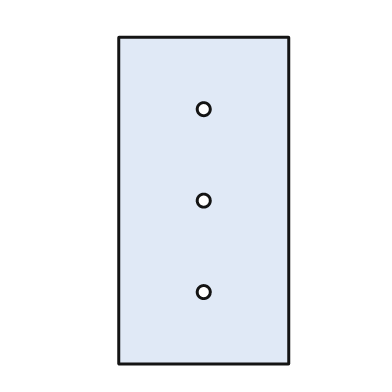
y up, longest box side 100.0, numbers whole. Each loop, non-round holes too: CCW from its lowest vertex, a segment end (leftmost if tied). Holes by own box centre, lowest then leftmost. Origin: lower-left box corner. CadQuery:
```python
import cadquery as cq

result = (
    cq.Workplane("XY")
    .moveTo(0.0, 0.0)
    .lineTo(52.0, 0.0)
    .lineTo(52.0, 100.0)
    .lineTo(0.0, 100.0)
    .close()
    .moveTo(26.0, 22.0)
    .circle(2.0)
    .moveTo(26.0, 50.0)
    .circle(2.0)
    .moveTo(26.0, 78.0)
    .circle(2.0)
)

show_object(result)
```